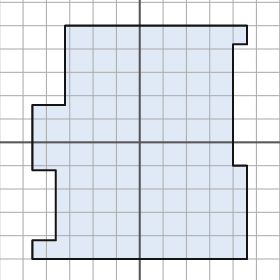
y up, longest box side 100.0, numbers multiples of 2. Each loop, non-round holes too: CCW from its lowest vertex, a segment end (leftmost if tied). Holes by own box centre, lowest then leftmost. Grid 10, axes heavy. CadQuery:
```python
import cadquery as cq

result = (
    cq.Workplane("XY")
    .moveTo(-46.0, -50.0)
    .lineTo(46.0, -50.0)
    .lineTo(46.0, -10.0)
    .lineTo(40.0, -10.0)
    .lineTo(40.0, 42.0)
    .lineTo(46.0, 42.0)
    .lineTo(46.0, 50.0)
    .lineTo(-32.0, 50.0)
    .lineTo(-32.0, 16.0)
    .lineTo(-46.0, 16.0)
    .lineTo(-46.0, -12.0)
    .lineTo(-36.0, -12.0)
    .lineTo(-36.0, -42.0)
    .lineTo(-46.0, -42.0)
    .close()
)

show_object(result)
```